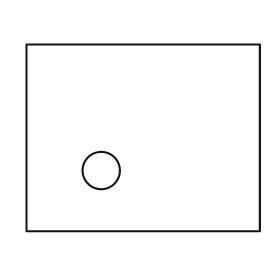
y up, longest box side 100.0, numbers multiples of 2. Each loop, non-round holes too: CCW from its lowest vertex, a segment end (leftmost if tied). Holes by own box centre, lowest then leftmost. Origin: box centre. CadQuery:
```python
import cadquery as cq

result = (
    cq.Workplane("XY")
    .moveTo(-50.0, -40.0)
    .lineTo(50.0, -40.0)
    .lineTo(50.0, 40.0)
    .lineTo(-50.0, 40.0)
    .close()
    .moveTo(-18.0, -14.0)
    .circle(8.0)
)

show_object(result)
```